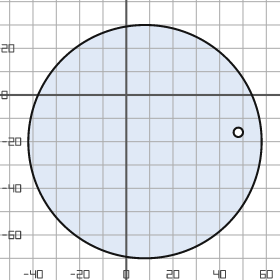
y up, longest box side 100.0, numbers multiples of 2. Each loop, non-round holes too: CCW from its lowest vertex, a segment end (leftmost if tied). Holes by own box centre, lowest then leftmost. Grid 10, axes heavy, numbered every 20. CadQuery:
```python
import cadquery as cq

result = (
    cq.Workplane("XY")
    .moveTo(8.0, -20.0)
    .circle(50.0)
    .moveTo(48.0, -16.0)
    .circle(2.0)
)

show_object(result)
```